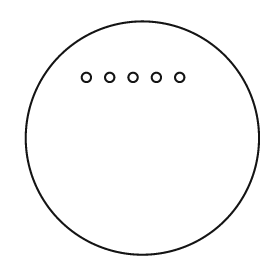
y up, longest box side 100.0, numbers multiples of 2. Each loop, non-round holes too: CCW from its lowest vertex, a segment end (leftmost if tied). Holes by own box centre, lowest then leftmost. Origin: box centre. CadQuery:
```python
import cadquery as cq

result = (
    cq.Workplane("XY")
    .moveTo(0.0, 0.0)
    .circle(50.0)
    .moveTo(-24.0, 26.0)
    .circle(2.0)
    .moveTo(-14.0, 26.0)
    .circle(2.0)
    .moveTo(-4.0, 26.0)
    .circle(2.0)
    .moveTo(6.0, 26.0)
    .circle(2.0)
    .moveTo(16.0, 26.0)
    .circle(2.0)
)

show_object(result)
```